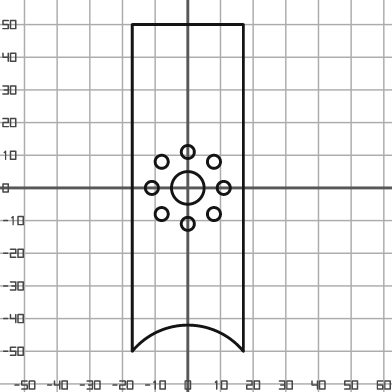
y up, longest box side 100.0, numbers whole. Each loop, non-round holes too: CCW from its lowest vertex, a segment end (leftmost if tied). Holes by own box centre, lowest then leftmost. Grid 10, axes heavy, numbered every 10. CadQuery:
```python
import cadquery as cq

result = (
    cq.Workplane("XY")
    .moveTo(-17.0, -50.0)
    .threePointArc((0.0, -42.0), (17.0, -50.0))
    .lineTo(17.0, 50.0)
    .lineTo(-17.0, 50.0)
    .close()
    .moveTo(0.0, -11.0)
    .circle(2.0)
    .moveTo(-8.0, -8.0)
    .circle(2.0)
    .moveTo(8.0, -8.0)
    .circle(2.0)
    .moveTo(-11.0, 0.0)
    .circle(2.0)
    .moveTo(0.0, 0.0)
    .circle(5.0)
    .moveTo(11.0, 0.0)
    .circle(2.0)
    .moveTo(-8.0, 8.0)
    .circle(2.0)
    .moveTo(8.0, 8.0)
    .circle(2.0)
    .moveTo(0.0, 11.0)
    .circle(2.0)
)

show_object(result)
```